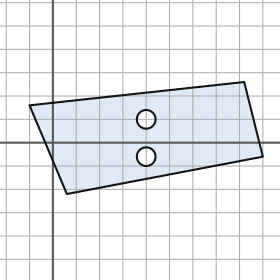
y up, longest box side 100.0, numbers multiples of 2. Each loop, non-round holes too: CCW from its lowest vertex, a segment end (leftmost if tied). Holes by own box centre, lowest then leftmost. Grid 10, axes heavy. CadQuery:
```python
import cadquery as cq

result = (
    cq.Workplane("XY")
    .moveTo(6.0, -22.0)
    .lineTo(90.0, -6.0)
    .lineTo(82.0, 26.0)
    .lineTo(-10.0, 16.0)
    .close()
    .moveTo(40.0, -6.0)
    .circle(4.0)
    .moveTo(40.0, 10.0)
    .circle(4.0)
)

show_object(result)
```